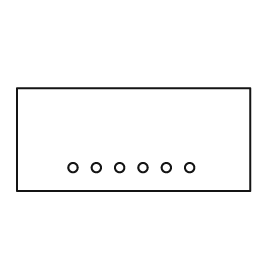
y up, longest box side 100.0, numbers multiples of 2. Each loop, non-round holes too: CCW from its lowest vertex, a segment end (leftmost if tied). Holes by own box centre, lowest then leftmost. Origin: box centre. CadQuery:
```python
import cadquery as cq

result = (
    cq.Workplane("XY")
    .moveTo(-50.0, -22.0)
    .lineTo(50.0, -22.0)
    .lineTo(50.0, 22.0)
    .lineTo(-50.0, 22.0)
    .close()
    .moveTo(-26.0, -12.0)
    .circle(2.0)
    .moveTo(-16.0, -12.0)
    .circle(2.0)
    .moveTo(-6.0, -12.0)
    .circle(2.0)
    .moveTo(4.0, -12.0)
    .circle(2.0)
    .moveTo(14.0, -12.0)
    .circle(2.0)
    .moveTo(24.0, -12.0)
    .circle(2.0)
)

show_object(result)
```